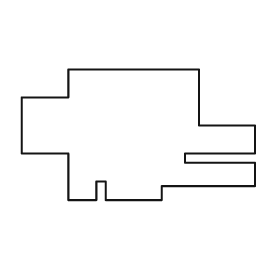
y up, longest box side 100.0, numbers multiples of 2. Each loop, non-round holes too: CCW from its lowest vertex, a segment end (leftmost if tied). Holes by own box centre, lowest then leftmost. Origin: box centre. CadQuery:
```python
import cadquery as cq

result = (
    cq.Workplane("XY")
    .moveTo(-30.0, -28.0)
    .lineTo(-18.0, -28.0)
    .lineTo(-18.0, -20.0)
    .lineTo(-14.0, -20.0)
    .lineTo(-14.0, -28.0)
    .lineTo(10.0, -28.0)
    .lineTo(10.0, -22.0)
    .lineTo(50.0, -22.0)
    .lineTo(50.0, -12.0)
    .lineTo(20.0, -12.0)
    .lineTo(20.0, -8.0)
    .lineTo(50.0, -8.0)
    .lineTo(50.0, 4.0)
    .lineTo(26.0, 4.0)
    .lineTo(26.0, 28.0)
    .lineTo(-30.0, 28.0)
    .lineTo(-30.0, 16.0)
    .lineTo(-50.0, 16.0)
    .lineTo(-50.0, -8.0)
    .lineTo(-30.0, -8.0)
    .close()
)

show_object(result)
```